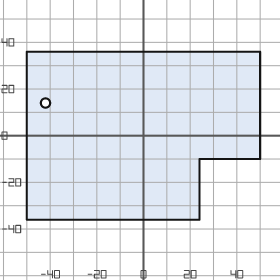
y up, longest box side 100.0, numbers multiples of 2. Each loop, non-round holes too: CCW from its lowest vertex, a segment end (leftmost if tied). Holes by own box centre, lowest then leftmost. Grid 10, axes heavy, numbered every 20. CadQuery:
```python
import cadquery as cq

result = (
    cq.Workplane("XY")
    .moveTo(-50.0, -36.0)
    .lineTo(24.0, -36.0)
    .lineTo(24.0, -10.0)
    .lineTo(50.0, -10.0)
    .lineTo(50.0, 36.0)
    .lineTo(-50.0, 36.0)
    .close()
    .moveTo(-42.0, 14.0)
    .circle(2.0)
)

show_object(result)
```